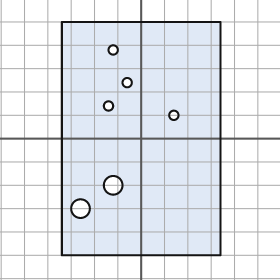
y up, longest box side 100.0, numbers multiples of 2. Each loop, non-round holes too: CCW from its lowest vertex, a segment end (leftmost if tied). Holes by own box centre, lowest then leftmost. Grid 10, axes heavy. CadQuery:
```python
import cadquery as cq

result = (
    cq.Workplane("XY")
    .moveTo(-34.0, -50.0)
    .lineTo(34.0, -50.0)
    .lineTo(34.0, 50.0)
    .lineTo(-34.0, 50.0)
    .close()
    .moveTo(-26.0, -30.0)
    .circle(4.0)
    .moveTo(-12.0, -20.0)
    .circle(4.0)
    .moveTo(14.0, 10.0)
    .circle(2.0)
    .moveTo(-14.0, 14.0)
    .circle(2.0)
    .moveTo(-6.0, 24.0)
    .circle(2.0)
    .moveTo(-12.0, 38.0)
    .circle(2.0)
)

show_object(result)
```